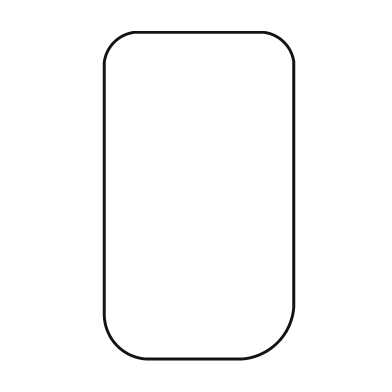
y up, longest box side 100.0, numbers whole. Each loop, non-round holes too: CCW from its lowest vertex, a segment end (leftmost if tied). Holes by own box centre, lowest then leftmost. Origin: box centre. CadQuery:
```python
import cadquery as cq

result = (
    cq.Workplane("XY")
    .moveTo(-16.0, -50.0)
    .lineTo(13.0, -50.0)
    .threePointArc((24.0, -45.0), (29.0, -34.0))
    .lineTo(29.0, 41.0)
    .threePointArc((26.0, 47.0), (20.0, 50.0))
    .lineTo(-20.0, 50.0)
    .threePointArc((-26.0, 47.0), (-29.0, 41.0))
    .lineTo(-29.0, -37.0)
    .threePointArc((-25.0, -46.0), (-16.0, -50.0))
    .close()
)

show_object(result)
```